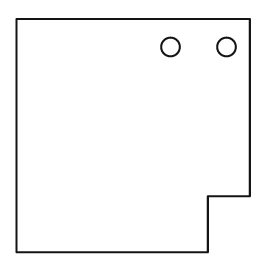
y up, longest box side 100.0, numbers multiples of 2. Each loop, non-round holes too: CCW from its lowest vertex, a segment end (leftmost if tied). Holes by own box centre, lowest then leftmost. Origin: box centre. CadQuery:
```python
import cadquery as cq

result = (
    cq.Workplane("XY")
    .moveTo(-50.0, -50.0)
    .lineTo(32.0, -50.0)
    .lineTo(32.0, -26.0)
    .lineTo(50.0, -26.0)
    .lineTo(50.0, 50.0)
    .lineTo(-50.0, 50.0)
    .close()
    .moveTo(16.0, 38.0)
    .circle(4.0)
    .moveTo(40.0, 38.0)
    .circle(4.0)
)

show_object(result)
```